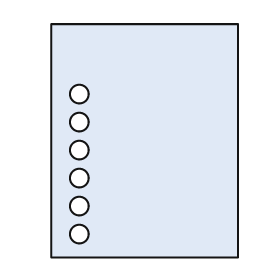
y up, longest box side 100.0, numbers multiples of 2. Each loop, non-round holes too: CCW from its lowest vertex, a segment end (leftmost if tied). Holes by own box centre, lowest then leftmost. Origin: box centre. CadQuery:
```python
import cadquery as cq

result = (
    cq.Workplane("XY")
    .moveTo(-40.0, -50.0)
    .lineTo(40.0, -50.0)
    .lineTo(40.0, 50.0)
    .lineTo(-40.0, 50.0)
    .close()
    .moveTo(-28.0, -40.0)
    .circle(4.0)
    .moveTo(-28.0, -28.0)
    .circle(4.0)
    .moveTo(-28.0, -16.0)
    .circle(4.0)
    .moveTo(-28.0, -4.0)
    .circle(4.0)
    .moveTo(-28.0, 8.0)
    .circle(4.0)
    .moveTo(-28.0, 20.0)
    .circle(4.0)
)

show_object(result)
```